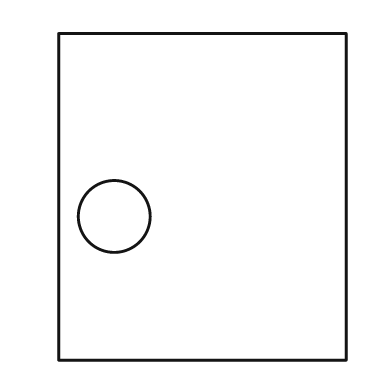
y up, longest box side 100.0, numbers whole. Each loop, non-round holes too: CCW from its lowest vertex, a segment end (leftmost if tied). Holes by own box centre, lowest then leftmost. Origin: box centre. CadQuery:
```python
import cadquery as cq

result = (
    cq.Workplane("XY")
    .moveTo(-44.0, -50.0)
    .lineTo(44.0, -50.0)
    .lineTo(44.0, 50.0)
    .lineTo(-44.0, 50.0)
    .close()
    .moveTo(-27.0, -6.0)
    .circle(11.0)
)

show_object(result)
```